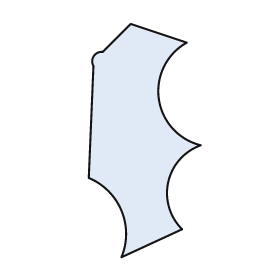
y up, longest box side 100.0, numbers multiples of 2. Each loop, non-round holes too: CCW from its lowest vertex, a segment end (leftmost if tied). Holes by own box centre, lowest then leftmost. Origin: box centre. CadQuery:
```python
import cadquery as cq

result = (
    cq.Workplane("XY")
    .moveTo(-10.0, -50.0)
    .lineTo(16.0, -38.0)
    .threePointArc((10.0, -18.0), (24.0, -2.0))
    .threePointArc((6.0, 18.0), (18.0, 42.0))
    .lineTo(-6.0, 50.0)
    .lineTo(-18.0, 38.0)
    .threePointArc((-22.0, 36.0), (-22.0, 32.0))
    .lineTo(-24.0, -16.0)
    .threePointArc((-10.0, -30.0), (-10.0, -50.0))
    .close()
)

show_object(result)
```